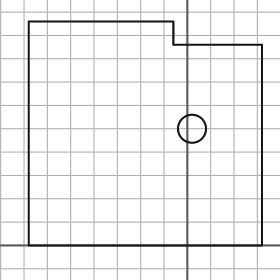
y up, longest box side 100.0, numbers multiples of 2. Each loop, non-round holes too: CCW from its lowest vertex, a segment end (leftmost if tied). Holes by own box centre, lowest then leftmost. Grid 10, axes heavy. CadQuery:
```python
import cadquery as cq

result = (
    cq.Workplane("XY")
    .moveTo(-68.0, 0.0)
    .lineTo(32.0, 0.0)
    .lineTo(32.0, 86.0)
    .lineTo(-6.0, 86.0)
    .lineTo(-6.0, 96.0)
    .lineTo(-68.0, 96.0)
    .close()
    .moveTo(2.0, 50.0)
    .circle(6.0)
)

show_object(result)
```